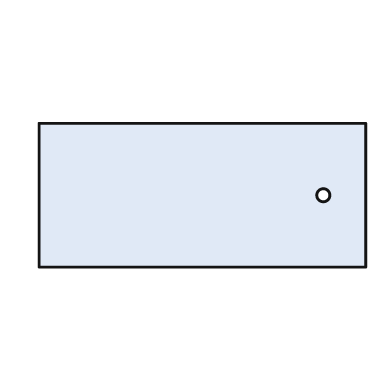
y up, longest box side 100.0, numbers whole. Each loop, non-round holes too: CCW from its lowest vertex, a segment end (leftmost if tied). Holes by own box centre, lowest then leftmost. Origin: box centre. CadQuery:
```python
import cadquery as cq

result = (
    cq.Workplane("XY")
    .moveTo(-50.0, -22.0)
    .lineTo(50.0, -22.0)
    .lineTo(50.0, 22.0)
    .lineTo(-50.0, 22.0)
    .close()
    .moveTo(37.0, 0.0)
    .circle(2.0)
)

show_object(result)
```